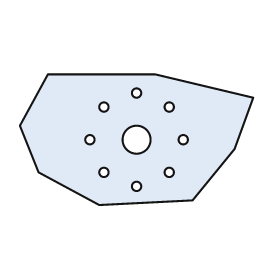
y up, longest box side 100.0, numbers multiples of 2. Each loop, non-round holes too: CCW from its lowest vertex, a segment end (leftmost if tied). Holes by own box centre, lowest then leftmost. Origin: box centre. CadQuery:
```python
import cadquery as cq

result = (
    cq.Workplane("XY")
    .moveTo(-16.0, -28.0)
    .lineTo(24.0, -26.0)
    .lineTo(42.0, -4.0)
    .lineTo(50.0, 18.0)
    .lineTo(8.0, 28.0)
    .lineTo(-38.0, 28.0)
    .lineTo(-50.0, 6.0)
    .lineTo(-42.0, -14.0)
    .close()
    .moveTo(0.0, -20.0)
    .circle(2.0)
    .moveTo(-14.0, -14.0)
    .circle(2.0)
    .moveTo(14.0, -14.0)
    .circle(2.0)
    .moveTo(-20.0, 0.0)
    .circle(2.0)
    .moveTo(0.0, 0.0)
    .circle(6.0)
    .moveTo(20.0, 0.0)
    .circle(2.0)
    .moveTo(-14.0, 14.0)
    .circle(2.0)
    .moveTo(14.0, 14.0)
    .circle(2.0)
    .moveTo(0.0, 20.0)
    .circle(2.0)
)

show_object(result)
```